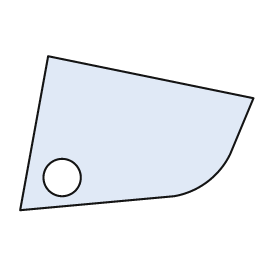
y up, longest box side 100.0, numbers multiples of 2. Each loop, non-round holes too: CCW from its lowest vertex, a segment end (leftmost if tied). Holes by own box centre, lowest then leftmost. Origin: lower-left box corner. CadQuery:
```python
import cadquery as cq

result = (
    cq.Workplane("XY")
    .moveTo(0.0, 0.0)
    .lineTo(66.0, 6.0)
    .threePointArc((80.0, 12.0), (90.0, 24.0))
    .lineTo(100.0, 48.0)
    .lineTo(12.0, 66.0)
    .close()
    .moveTo(18.0, 14.0)
    .circle(8.0)
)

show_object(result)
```